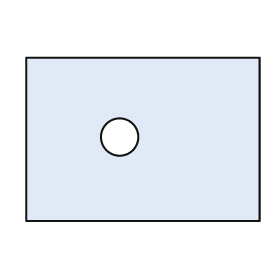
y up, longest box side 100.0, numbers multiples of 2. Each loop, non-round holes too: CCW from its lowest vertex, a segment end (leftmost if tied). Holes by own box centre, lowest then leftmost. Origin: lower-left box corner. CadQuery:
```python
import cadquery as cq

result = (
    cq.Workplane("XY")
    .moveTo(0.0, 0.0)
    .lineTo(100.0, 0.0)
    .lineTo(100.0, 70.0)
    .lineTo(0.0, 70.0)
    .close()
    .moveTo(40.0, 36.0)
    .circle(8.0)
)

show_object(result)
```